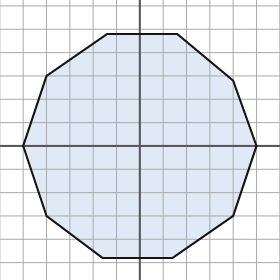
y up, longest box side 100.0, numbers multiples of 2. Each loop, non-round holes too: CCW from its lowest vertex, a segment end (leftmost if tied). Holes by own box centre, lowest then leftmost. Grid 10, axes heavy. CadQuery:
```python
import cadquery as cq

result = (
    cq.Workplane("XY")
    .moveTo(-16.0, -48.0)
    .lineTo(14.0, -48.0)
    .lineTo(40.0, -30.0)
    .lineTo(50.0, 0.0)
    .lineTo(40.0, 28.0)
    .lineTo(16.0, 48.0)
    .lineTo(-14.0, 48.0)
    .lineTo(-40.0, 30.0)
    .lineTo(-50.0, 0.0)
    .lineTo(-40.0, -30.0)
    .close()
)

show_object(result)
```